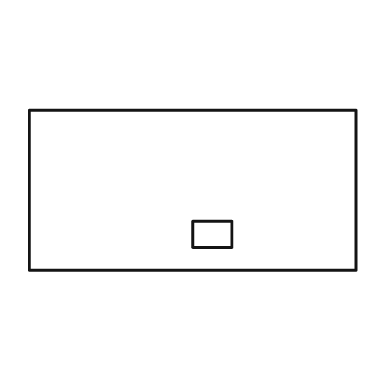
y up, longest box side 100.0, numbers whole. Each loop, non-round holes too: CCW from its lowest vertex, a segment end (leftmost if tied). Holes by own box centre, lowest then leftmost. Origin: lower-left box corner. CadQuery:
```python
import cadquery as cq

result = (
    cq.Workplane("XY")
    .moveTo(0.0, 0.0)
    .lineTo(100.0, 0.0)
    .lineTo(100.0, 49.0)
    .lineTo(0.0, 49.0)
    .close()
    .moveTo(50.0, 7.0)
    .lineTo(62.0, 7.0)
    .lineTo(62.0, 15.0)
    .lineTo(50.0, 15.0)
    .close()
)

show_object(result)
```